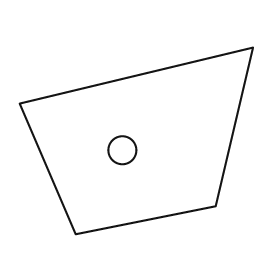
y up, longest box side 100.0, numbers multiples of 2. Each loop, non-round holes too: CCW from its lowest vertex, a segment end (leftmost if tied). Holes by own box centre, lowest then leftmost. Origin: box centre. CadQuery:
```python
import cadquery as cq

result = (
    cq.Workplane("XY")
    .moveTo(-26.0, -40.0)
    .lineTo(34.0, -28.0)
    .lineTo(50.0, 40.0)
    .lineTo(-50.0, 16.0)
    .close()
    .moveTo(-6.0, -4.0)
    .circle(6.0)
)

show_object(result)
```